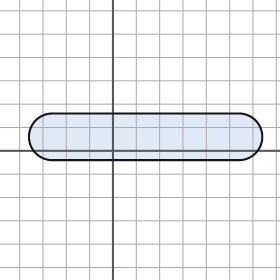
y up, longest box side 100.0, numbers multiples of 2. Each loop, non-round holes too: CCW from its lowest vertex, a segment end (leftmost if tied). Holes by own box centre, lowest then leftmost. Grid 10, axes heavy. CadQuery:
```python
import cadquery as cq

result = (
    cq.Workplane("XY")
    .moveTo(-26.0, -4.0)
    .lineTo(54.0, -4.0)
    .threePointArc((64.0, 6.0), (54.0, 16.0))
    .lineTo(-26.0, 16.0)
    .threePointArc((-36.0, 6.0), (-26.0, -4.0))
    .close()
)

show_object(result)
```